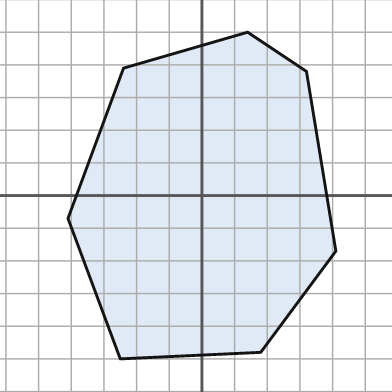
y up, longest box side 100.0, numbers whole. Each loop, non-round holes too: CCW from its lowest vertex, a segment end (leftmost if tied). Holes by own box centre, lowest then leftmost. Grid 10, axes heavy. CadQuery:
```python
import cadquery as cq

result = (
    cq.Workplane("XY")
    .moveTo(-25.0, -50.0)
    .lineTo(18.0, -48.0)
    .lineTo(41.0, -17.0)
    .lineTo(32.0, 38.0)
    .lineTo(14.0, 50.0)
    .lineTo(-24.0, 39.0)
    .lineTo(-41.0, -7.0)
    .close()
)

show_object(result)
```